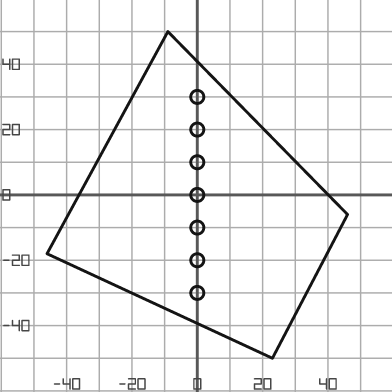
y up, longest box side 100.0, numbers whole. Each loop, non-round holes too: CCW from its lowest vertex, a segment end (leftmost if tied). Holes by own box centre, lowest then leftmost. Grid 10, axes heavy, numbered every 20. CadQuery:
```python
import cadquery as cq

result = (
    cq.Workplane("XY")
    .moveTo(23.0, -50.0)
    .lineTo(46.0, -6.0)
    .lineTo(-9.0, 50.0)
    .lineTo(-46.0, -18.0)
    .close()
    .moveTo(0.0, -30.0)
    .circle(2.0)
    .moveTo(0.0, -20.0)
    .circle(2.0)
    .moveTo(0.0, -10.0)
    .circle(2.0)
    .moveTo(0.0, 0.0)
    .circle(2.0)
    .moveTo(0.0, 10.0)
    .circle(2.0)
    .moveTo(0.0, 20.0)
    .circle(2.0)
    .moveTo(0.0, 30.0)
    .circle(2.0)
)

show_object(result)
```